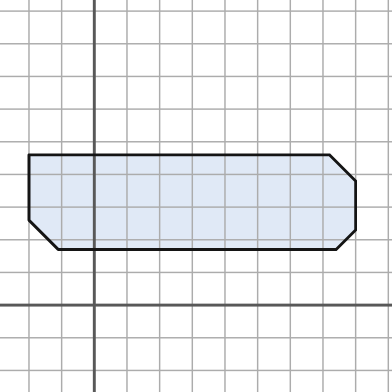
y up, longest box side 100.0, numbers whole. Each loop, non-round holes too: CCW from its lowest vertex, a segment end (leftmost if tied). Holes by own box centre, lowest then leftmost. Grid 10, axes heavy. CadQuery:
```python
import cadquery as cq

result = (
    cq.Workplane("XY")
    .moveTo(-11.0, 17.0)
    .lineTo(74.0, 17.0)
    .lineTo(80.0, 23.0)
    .lineTo(80.0, 38.0)
    .lineTo(72.0, 46.0)
    .lineTo(-20.0, 46.0)
    .lineTo(-20.0, 26.0)
    .close()
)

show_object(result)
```